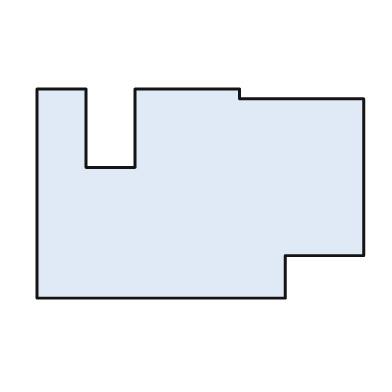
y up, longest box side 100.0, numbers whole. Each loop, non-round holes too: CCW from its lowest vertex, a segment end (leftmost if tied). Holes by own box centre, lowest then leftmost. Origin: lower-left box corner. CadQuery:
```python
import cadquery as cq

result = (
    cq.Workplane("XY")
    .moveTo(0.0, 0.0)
    .lineTo(76.0, 0.0)
    .lineTo(76.0, 13.0)
    .lineTo(100.0, 13.0)
    .lineTo(100.0, 61.0)
    .lineTo(62.0, 61.0)
    .lineTo(62.0, 64.0)
    .lineTo(30.0, 64.0)
    .lineTo(30.0, 40.0)
    .lineTo(15.0, 40.0)
    .lineTo(15.0, 64.0)
    .lineTo(0.0, 64.0)
    .close()
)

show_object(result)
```